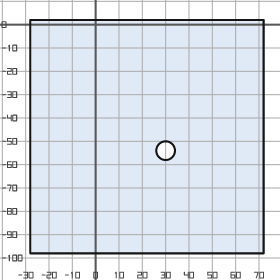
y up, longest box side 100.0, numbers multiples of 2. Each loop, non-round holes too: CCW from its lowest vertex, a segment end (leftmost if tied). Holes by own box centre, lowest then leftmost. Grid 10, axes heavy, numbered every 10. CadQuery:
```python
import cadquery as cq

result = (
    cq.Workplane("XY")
    .moveTo(-28.0, -98.0)
    .lineTo(72.0, -98.0)
    .lineTo(72.0, 2.0)
    .lineTo(-28.0, 2.0)
    .close()
    .moveTo(30.0, -54.0)
    .circle(4.0)
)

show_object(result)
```